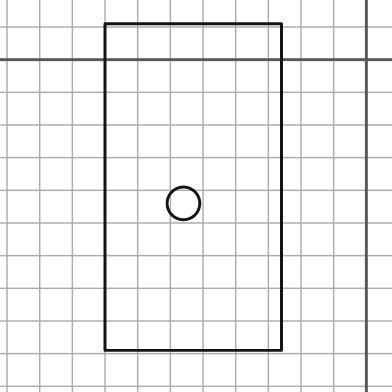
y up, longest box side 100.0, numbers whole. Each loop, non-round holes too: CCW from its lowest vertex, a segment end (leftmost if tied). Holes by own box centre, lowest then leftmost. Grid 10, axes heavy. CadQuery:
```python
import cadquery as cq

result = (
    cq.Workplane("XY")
    .moveTo(-80.0, -89.0)
    .lineTo(-26.0, -89.0)
    .lineTo(-26.0, 11.0)
    .lineTo(-80.0, 11.0)
    .close()
    .moveTo(-56.0, -44.0)
    .circle(5.0)
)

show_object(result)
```